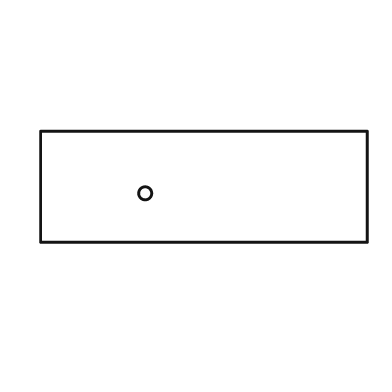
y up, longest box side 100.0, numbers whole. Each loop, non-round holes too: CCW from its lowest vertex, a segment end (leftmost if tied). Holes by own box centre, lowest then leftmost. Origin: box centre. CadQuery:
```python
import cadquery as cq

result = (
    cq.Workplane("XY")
    .moveTo(-50.0, -17.0)
    .lineTo(50.0, -17.0)
    .lineTo(50.0, 17.0)
    .lineTo(-50.0, 17.0)
    .close()
    .moveTo(-18.0, -2.0)
    .circle(2.0)
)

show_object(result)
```